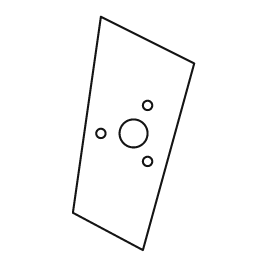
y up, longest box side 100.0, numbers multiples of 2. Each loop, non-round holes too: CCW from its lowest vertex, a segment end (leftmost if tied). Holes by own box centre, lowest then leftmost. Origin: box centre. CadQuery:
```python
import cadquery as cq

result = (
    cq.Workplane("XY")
    .moveTo(4.0, -50.0)
    .lineTo(26.0, 30.0)
    .lineTo(-14.0, 50.0)
    .lineTo(-26.0, -34.0)
    .close()
    .moveTo(6.0, -12.0)
    .circle(2.0)
    .moveTo(-14.0, 0.0)
    .circle(2.0)
    .moveTo(0.0, 0.0)
    .circle(6.0)
    .moveTo(6.0, 12.0)
    .circle(2.0)
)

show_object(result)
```